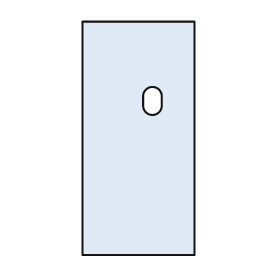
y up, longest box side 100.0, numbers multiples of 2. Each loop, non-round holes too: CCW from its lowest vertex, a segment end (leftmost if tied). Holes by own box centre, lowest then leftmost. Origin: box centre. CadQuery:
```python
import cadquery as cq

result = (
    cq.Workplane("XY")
    .moveTo(-24.0, -50.0)
    .lineTo(24.0, -50.0)
    .lineTo(24.0, 50.0)
    .lineTo(-24.0, 50.0)
    .close()
    .moveTo(2.0, 14.0)
    .threePointArc((6.0, 10.0), (10.0, 14.0))
    .lineTo(10.0, 18.0)
    .threePointArc((6.0, 22.0), (2.0, 18.0))
    .close()
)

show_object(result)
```